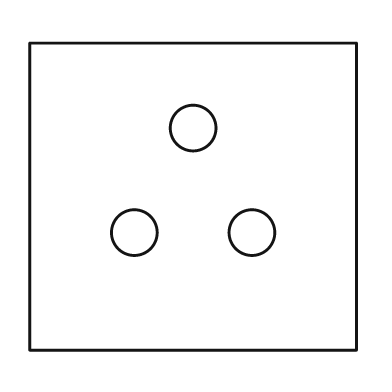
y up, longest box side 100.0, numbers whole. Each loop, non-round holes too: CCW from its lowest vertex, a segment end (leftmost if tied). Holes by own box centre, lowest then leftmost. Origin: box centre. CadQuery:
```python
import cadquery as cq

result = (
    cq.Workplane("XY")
    .moveTo(-50.0, -47.0)
    .lineTo(50.0, -47.0)
    .lineTo(50.0, 47.0)
    .lineTo(-50.0, 47.0)
    .close()
    .moveTo(-18.0, -11.0)
    .circle(7.0)
    .moveTo(18.0, -11.0)
    .circle(7.0)
    .moveTo(0.0, 21.0)
    .circle(7.0)
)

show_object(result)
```